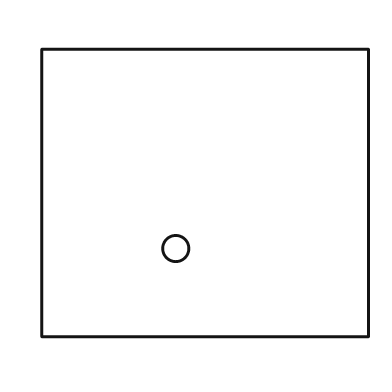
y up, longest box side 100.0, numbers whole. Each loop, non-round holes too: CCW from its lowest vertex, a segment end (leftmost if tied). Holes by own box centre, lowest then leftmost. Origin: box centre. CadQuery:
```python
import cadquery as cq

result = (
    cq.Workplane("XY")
    .moveTo(-50.0, -44.0)
    .lineTo(50.0, -44.0)
    .lineTo(50.0, 44.0)
    .lineTo(-50.0, 44.0)
    .close()
    .moveTo(-9.0, -17.0)
    .circle(4.0)
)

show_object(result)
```